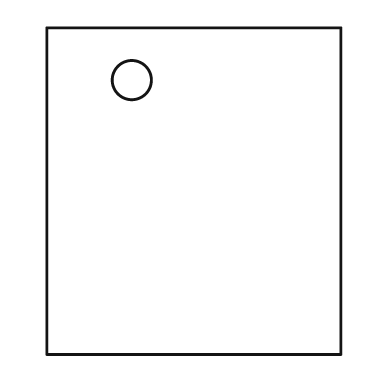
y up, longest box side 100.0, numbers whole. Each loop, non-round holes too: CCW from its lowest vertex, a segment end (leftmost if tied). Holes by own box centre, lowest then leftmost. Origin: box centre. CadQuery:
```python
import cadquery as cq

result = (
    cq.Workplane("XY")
    .moveTo(-45.0, -50.0)
    .lineTo(45.0, -50.0)
    .lineTo(45.0, 50.0)
    .lineTo(-45.0, 50.0)
    .close()
    .moveTo(-19.0, 34.0)
    .circle(6.0)
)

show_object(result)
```